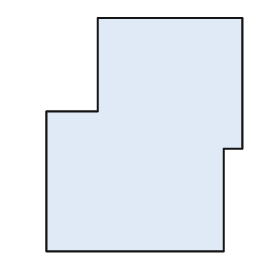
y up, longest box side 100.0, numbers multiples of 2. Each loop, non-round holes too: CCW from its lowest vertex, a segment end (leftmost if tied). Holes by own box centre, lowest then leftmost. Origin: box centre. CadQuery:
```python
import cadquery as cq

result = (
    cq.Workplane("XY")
    .moveTo(-42.0, -50.0)
    .lineTo(34.0, -50.0)
    .lineTo(34.0, -6.0)
    .lineTo(42.0, -6.0)
    .lineTo(42.0, 50.0)
    .lineTo(-20.0, 50.0)
    .lineTo(-20.0, 10.0)
    .lineTo(-42.0, 10.0)
    .close()
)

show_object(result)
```